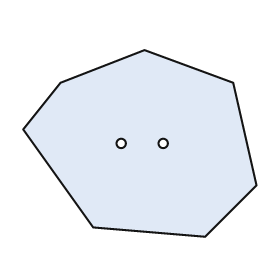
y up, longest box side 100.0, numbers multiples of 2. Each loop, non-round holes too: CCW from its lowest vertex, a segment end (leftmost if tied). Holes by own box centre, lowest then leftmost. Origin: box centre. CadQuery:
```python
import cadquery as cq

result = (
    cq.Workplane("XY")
    .moveTo(28.0, -40.0)
    .lineTo(50.0, -18.0)
    .lineTo(40.0, 26.0)
    .lineTo(2.0, 40.0)
    .lineTo(-34.0, 26.0)
    .lineTo(-50.0, 6.0)
    .lineTo(-20.0, -36.0)
    .close()
    .moveTo(-8.0, 0.0)
    .circle(2.0)
    .moveTo(10.0, 0.0)
    .circle(2.0)
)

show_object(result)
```